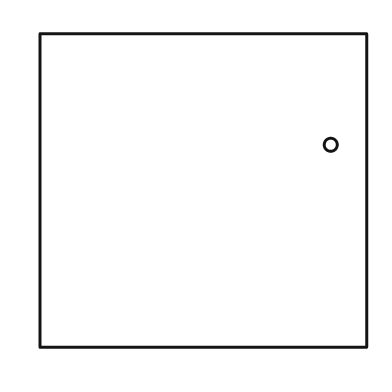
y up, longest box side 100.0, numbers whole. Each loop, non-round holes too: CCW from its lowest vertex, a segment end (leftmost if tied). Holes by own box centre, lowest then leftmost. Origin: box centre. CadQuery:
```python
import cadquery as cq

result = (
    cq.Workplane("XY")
    .moveTo(-50.0, -48.0)
    .lineTo(50.0, -48.0)
    .lineTo(50.0, 48.0)
    .lineTo(-50.0, 48.0)
    .close()
    .moveTo(39.0, 14.0)
    .circle(2.0)
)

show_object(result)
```